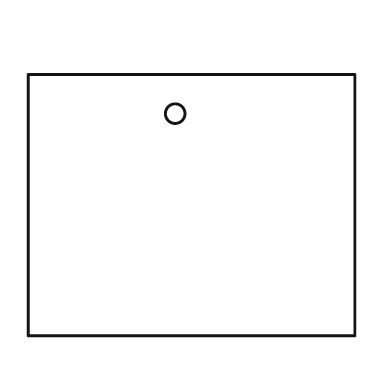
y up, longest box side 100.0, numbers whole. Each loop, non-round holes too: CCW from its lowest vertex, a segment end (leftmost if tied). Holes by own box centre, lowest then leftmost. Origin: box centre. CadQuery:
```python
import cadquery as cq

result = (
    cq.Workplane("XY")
    .moveTo(-50.0, -40.0)
    .lineTo(50.0, -40.0)
    .lineTo(50.0, 40.0)
    .lineTo(-50.0, 40.0)
    .close()
    .moveTo(-5.0, 28.0)
    .circle(3.0)
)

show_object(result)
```